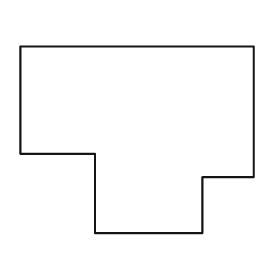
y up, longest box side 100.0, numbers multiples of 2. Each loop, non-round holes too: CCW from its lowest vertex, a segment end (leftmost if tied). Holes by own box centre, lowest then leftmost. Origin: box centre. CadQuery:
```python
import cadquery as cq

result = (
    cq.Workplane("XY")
    .moveTo(-18.0, -40.0)
    .lineTo(28.0, -40.0)
    .lineTo(28.0, -16.0)
    .lineTo(50.0, -16.0)
    .lineTo(50.0, 40.0)
    .lineTo(-50.0, 40.0)
    .lineTo(-50.0, -6.0)
    .lineTo(-18.0, -6.0)
    .close()
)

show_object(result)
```